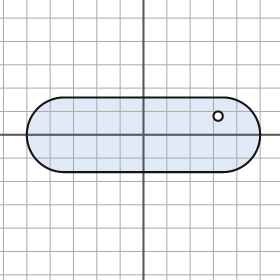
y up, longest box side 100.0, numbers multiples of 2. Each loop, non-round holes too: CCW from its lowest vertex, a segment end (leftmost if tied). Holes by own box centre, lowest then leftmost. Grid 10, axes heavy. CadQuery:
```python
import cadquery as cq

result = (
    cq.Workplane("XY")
    .moveTo(-34.0, -16.0)
    .lineTo(34.0, -16.0)
    .threePointArc((50.0, 0.0), (34.0, 16.0))
    .lineTo(-34.0, 16.0)
    .threePointArc((-50.0, 0.0), (-34.0, -16.0))
    .close()
    .moveTo(32.0, 8.0)
    .circle(2.0)
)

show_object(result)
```